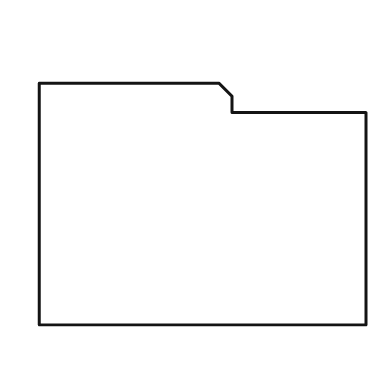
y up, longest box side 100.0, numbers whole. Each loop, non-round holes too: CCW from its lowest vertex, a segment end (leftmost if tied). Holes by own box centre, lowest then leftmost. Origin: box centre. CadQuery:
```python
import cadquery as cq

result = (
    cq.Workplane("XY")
    .moveTo(-50.0, -37.0)
    .lineTo(50.0, -37.0)
    .lineTo(50.0, 28.0)
    .lineTo(9.0, 28.0)
    .lineTo(9.0, 33.0)
    .lineTo(5.0, 37.0)
    .lineTo(-50.0, 37.0)
    .close()
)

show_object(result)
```